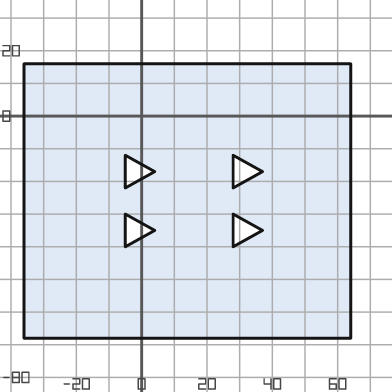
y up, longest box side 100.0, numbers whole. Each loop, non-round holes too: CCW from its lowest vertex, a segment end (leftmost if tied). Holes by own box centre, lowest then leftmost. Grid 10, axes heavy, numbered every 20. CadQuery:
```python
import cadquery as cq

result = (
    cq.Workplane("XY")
    .moveTo(-36.0, -68.0)
    .lineTo(64.0, -68.0)
    .lineTo(64.0, 16.0)
    .lineTo(-36.0, 16.0)
    .close()
    .moveTo(-5.0, -40.0)
    .lineTo(4.0, -35.0)
    .lineTo(-5.0, -30.0)
    .close()
    .moveTo(28.0, -40.0)
    .lineTo(37.0, -35.0)
    .lineTo(28.0, -30.0)
    .close()
    .moveTo(-5.0, -22.0)
    .lineTo(4.0, -17.0)
    .lineTo(-5.0, -12.0)
    .close()
    .moveTo(28.0, -22.0)
    .lineTo(37.0, -17.0)
    .lineTo(28.0, -12.0)
    .close()
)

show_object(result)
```